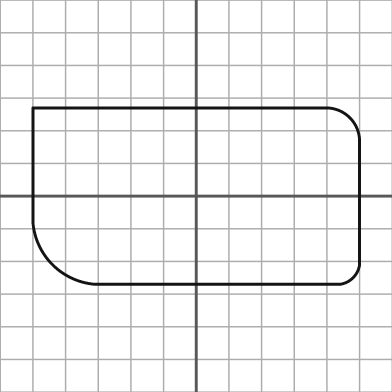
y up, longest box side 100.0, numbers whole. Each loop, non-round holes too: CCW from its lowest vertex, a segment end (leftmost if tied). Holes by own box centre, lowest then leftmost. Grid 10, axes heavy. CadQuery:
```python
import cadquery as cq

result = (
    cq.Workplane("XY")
    .moveTo(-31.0, -27.0)
    .lineTo(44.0, -27.0)
    .threePointArc((48.0, -25.0), (50.0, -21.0))
    .lineTo(50.0, 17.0)
    .threePointArc((47.0, 24.0), (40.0, 27.0))
    .lineTo(-50.0, 27.0)
    .lineTo(-50.0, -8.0)
    .threePointArc((-44.0, -21.0), (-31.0, -27.0))
    .close()
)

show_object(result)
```